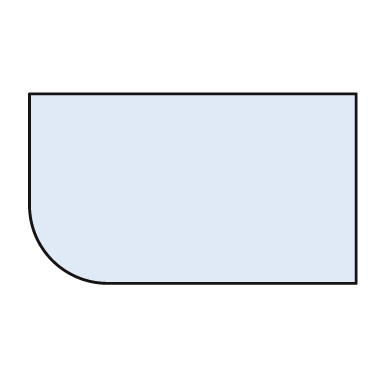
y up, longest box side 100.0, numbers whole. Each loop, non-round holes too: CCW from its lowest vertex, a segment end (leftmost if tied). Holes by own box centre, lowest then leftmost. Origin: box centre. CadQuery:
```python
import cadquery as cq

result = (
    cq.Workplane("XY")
    .moveTo(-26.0, -29.0)
    .lineTo(50.0, -29.0)
    .lineTo(50.0, 29.0)
    .lineTo(-50.0, 29.0)
    .lineTo(-50.0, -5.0)
    .threePointArc((-43.0, -22.0), (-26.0, -29.0))
    .close()
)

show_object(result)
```